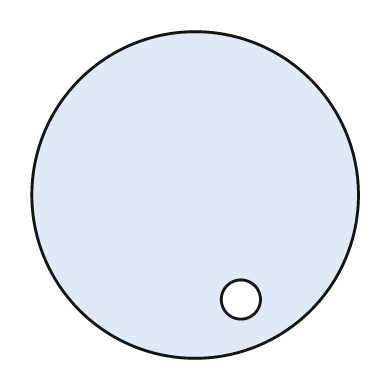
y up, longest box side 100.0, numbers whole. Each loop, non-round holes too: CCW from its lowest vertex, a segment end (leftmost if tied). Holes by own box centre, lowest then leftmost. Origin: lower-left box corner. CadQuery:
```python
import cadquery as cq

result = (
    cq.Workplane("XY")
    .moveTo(50.0, 50.0)
    .circle(50.0)
    .moveTo(64.0, 18.0)
    .circle(6.0)
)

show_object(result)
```